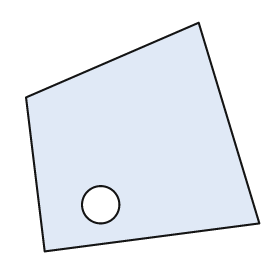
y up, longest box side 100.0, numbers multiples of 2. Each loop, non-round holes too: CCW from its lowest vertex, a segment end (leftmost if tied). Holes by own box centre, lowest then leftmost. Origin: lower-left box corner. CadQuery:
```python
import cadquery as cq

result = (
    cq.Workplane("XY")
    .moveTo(8.0, 0.0)
    .lineTo(100.0, 12.0)
    .lineTo(74.0, 98.0)
    .lineTo(0.0, 66.0)
    .close()
    .moveTo(32.0, 20.0)
    .circle(8.0)
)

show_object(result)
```